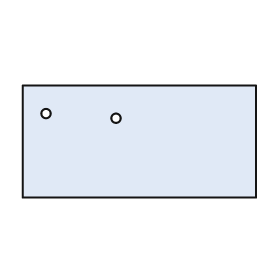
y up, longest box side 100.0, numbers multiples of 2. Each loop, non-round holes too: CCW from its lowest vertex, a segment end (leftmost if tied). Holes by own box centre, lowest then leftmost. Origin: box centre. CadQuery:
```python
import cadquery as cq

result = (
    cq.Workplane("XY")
    .moveTo(-50.0, -24.0)
    .lineTo(50.0, -24.0)
    .lineTo(50.0, 24.0)
    .lineTo(-50.0, 24.0)
    .close()
    .moveTo(-10.0, 10.0)
    .circle(2.0)
    .moveTo(-40.0, 12.0)
    .circle(2.0)
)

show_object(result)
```